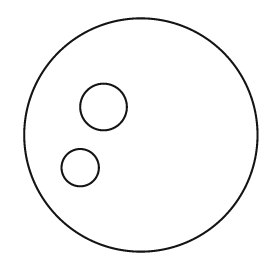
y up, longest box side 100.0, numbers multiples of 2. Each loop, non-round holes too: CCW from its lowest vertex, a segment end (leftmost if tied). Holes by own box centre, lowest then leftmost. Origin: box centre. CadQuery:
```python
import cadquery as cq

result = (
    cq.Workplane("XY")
    .moveTo(0.0, 0.0)
    .circle(50.0)
    .moveTo(-26.0, -14.0)
    .circle(8.0)
    .moveTo(-16.0, 12.0)
    .circle(10.0)
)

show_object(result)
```